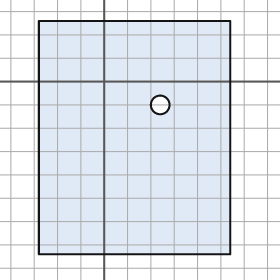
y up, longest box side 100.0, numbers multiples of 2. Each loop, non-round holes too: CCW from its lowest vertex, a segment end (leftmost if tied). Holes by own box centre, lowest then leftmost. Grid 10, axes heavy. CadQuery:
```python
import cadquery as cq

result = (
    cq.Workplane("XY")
    .moveTo(-28.0, -74.0)
    .lineTo(54.0, -74.0)
    .lineTo(54.0, 26.0)
    .lineTo(-28.0, 26.0)
    .close()
    .moveTo(24.0, -10.0)
    .circle(4.0)
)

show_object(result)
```